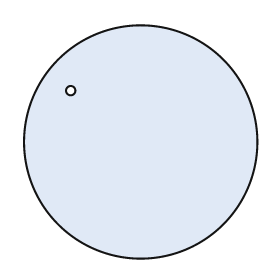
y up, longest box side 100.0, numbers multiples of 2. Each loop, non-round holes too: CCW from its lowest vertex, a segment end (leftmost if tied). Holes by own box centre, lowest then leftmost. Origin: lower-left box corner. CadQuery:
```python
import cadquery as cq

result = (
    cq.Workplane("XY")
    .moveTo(50.0, 50.0)
    .circle(50.0)
    .moveTo(20.0, 72.0)
    .circle(2.0)
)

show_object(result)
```